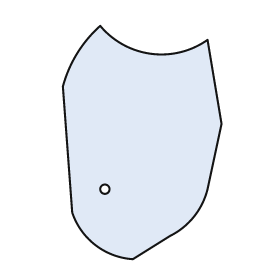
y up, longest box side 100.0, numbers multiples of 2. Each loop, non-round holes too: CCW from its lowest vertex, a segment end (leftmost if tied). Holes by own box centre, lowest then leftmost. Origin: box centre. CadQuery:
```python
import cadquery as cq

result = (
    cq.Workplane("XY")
    .moveTo(-4.0, -50.0)
    .lineTo(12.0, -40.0)
    .threePointArc((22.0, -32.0), (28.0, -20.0))
    .lineTo(34.0, 8.0)
    .lineTo(28.0, 44.0)
    .threePointArc((4.0, 38.0), (-18.0, 50.0))
    .threePointArc((-28.0, 38.0), (-34.0, 24.0))
    .lineTo(-30.0, -30.0)
    .threePointArc((-20.0, -44.0), (-4.0, -50.0))
    .close()
    .moveTo(-16.0, -20.0)
    .circle(2.0)
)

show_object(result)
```